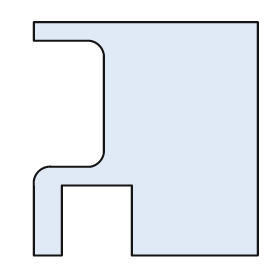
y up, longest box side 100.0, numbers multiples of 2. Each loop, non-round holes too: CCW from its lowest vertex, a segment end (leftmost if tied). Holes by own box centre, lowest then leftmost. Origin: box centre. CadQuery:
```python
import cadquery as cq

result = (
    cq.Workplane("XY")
    .moveTo(-48.0, -50.0)
    .lineTo(-36.0, -50.0)
    .lineTo(-36.0, -20.0)
    .lineTo(-6.0, -20.0)
    .lineTo(-6.0, -50.0)
    .lineTo(48.0, -50.0)
    .lineTo(48.0, 50.0)
    .lineTo(-48.0, 50.0)
    .lineTo(-48.0, 42.0)
    .lineTo(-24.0, 42.0)
    .threePointArc((-20.0, 40.0), (-18.0, 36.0))
    .lineTo(-18.0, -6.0)
    .threePointArc((-20.0, -10.0), (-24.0, -12.0))
    .lineTo(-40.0, -12.0)
    .threePointArc((-46.0, -14.0), (-48.0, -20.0))
    .close()
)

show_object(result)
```